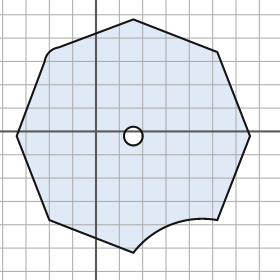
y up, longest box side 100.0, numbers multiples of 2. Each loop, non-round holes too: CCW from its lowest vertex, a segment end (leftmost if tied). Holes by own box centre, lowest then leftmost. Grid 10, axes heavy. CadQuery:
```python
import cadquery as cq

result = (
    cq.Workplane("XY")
    .moveTo(16.0, -52.0)
    .threePointArc((32.0, -40.0), (52.0, -38.0))
    .lineTo(66.0, -2.0)
    .lineTo(52.0, 34.0)
    .lineTo(16.0, 48.0)
    .lineTo(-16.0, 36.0)
    .threePointArc((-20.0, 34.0), (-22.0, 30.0))
    .lineTo(-34.0, -2.0)
    .lineTo(-20.0, -38.0)
    .close()
    .moveTo(16.0, -2.0)
    .circle(4.0)
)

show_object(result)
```